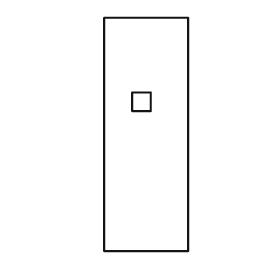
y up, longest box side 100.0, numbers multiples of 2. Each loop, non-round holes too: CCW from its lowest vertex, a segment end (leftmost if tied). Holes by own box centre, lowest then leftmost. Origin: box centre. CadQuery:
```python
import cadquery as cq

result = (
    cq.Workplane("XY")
    .moveTo(-18.0, -50.0)
    .lineTo(18.0, -50.0)
    .lineTo(18.0, 50.0)
    .lineTo(-18.0, 50.0)
    .close()
    .moveTo(-6.0, 10.0)
    .lineTo(2.0, 10.0)
    .lineTo(2.0, 18.0)
    .lineTo(-6.0, 18.0)
    .close()
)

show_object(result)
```